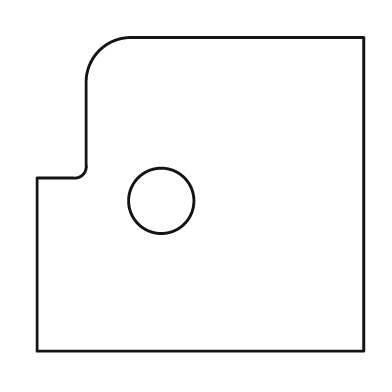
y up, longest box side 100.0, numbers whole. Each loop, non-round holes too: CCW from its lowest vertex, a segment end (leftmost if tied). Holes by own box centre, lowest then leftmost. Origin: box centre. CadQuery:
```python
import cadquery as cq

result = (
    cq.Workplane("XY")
    .moveTo(-50.0, -48.0)
    .lineTo(50.0, -48.0)
    .lineTo(50.0, 48.0)
    .lineTo(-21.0, 48.0)
    .threePointArc((-31.0, 44.0), (-35.0, 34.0))
    .lineTo(-35.0, 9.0)
    .threePointArc((-36.0, 6.0), (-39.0, 5.0))
    .lineTo(-50.0, 5.0)
    .close()
    .moveTo(-12.0, -2.0)
    .circle(10.0)
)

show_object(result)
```